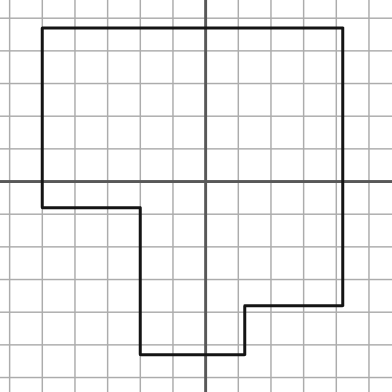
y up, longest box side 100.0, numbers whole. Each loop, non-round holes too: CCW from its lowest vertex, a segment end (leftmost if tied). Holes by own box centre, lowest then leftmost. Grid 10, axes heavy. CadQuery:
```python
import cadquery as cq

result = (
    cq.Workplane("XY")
    .moveTo(-20.0, -53.0)
    .lineTo(12.0, -53.0)
    .lineTo(12.0, -38.0)
    .lineTo(42.0, -38.0)
    .lineTo(42.0, 47.0)
    .lineTo(-50.0, 47.0)
    .lineTo(-50.0, -8.0)
    .lineTo(-20.0, -8.0)
    .close()
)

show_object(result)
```